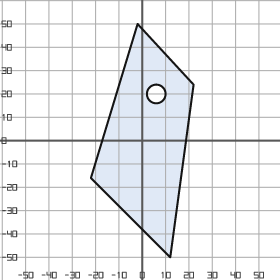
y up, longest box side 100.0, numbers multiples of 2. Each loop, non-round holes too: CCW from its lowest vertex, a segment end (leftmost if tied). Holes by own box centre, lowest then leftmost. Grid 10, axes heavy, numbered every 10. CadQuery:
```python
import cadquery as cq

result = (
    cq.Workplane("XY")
    .moveTo(12.0, -50.0)
    .lineTo(22.0, 24.0)
    .lineTo(-2.0, 50.0)
    .lineTo(-22.0, -16.0)
    .close()
    .moveTo(6.0, 20.0)
    .circle(4.0)
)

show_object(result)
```